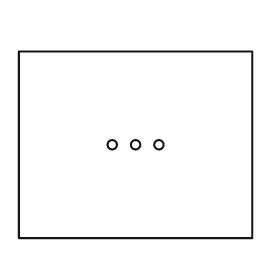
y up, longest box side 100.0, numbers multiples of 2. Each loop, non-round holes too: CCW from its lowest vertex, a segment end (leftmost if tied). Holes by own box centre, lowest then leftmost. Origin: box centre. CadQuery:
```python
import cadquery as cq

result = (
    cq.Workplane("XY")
    .moveTo(-50.0, -40.0)
    .lineTo(50.0, -40.0)
    .lineTo(50.0, 40.0)
    .lineTo(-50.0, 40.0)
    .close()
    .moveTo(-10.0, 0.0)
    .circle(2.0)
    .moveTo(0.0, 0.0)
    .circle(2.0)
    .moveTo(10.0, 0.0)
    .circle(2.0)
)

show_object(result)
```